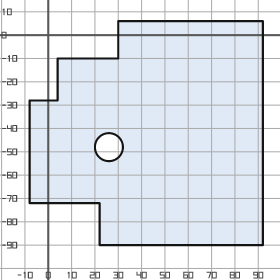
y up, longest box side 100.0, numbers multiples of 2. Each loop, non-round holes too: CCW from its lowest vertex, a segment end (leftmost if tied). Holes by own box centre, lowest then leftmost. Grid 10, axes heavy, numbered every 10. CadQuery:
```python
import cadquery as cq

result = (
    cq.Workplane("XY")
    .moveTo(22.0, -90.0)
    .lineTo(92.0, -90.0)
    .lineTo(92.0, 6.0)
    .lineTo(30.0, 6.0)
    .lineTo(30.0, -10.0)
    .lineTo(4.0, -10.0)
    .lineTo(4.0, -28.0)
    .lineTo(-8.0, -28.0)
    .lineTo(-8.0, -72.0)
    .lineTo(22.0, -72.0)
    .close()
    .moveTo(26.0, -48.0)
    .circle(6.0)
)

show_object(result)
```